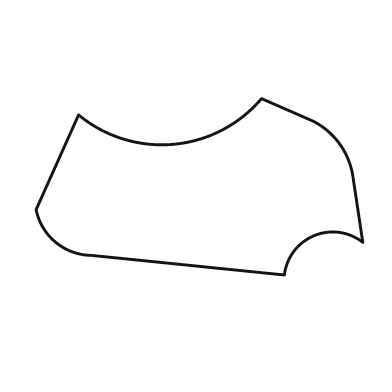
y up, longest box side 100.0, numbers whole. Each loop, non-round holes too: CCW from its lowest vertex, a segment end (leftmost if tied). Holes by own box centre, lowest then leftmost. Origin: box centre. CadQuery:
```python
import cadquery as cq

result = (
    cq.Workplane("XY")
    .moveTo(26.0, -27.0)
    .threePointArc((35.0, -15.0), (50.0, -17.0))
    .lineTo(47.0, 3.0)
    .threePointArc((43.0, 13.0), (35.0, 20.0))
    .lineTo(19.0, 27.0)
    .threePointArc((-8.0, 13.0), (-37.0, 22.0))
    .lineTo(-50.0, -7.0)
    .threePointArc((-44.0, -17.0), (-33.0, -21.0))
    .close()
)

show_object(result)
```